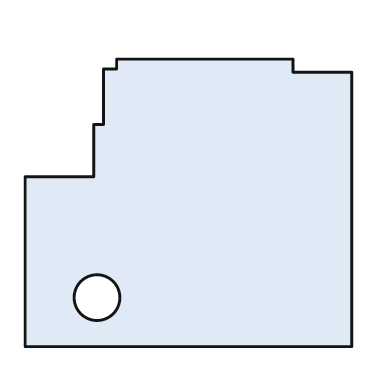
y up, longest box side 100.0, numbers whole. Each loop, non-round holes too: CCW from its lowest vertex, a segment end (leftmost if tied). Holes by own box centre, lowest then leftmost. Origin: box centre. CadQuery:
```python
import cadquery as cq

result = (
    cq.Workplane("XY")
    .moveTo(-50.0, -44.0)
    .lineTo(50.0, -44.0)
    .lineTo(50.0, 40.0)
    .lineTo(32.0, 40.0)
    .lineTo(32.0, 44.0)
    .lineTo(-22.0, 44.0)
    .lineTo(-22.0, 41.0)
    .lineTo(-26.0, 41.0)
    .lineTo(-26.0, 24.0)
    .lineTo(-29.0, 24.0)
    .lineTo(-29.0, 8.0)
    .lineTo(-50.0, 8.0)
    .close()
    .moveTo(-28.0, -29.0)
    .circle(7.0)
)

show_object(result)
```